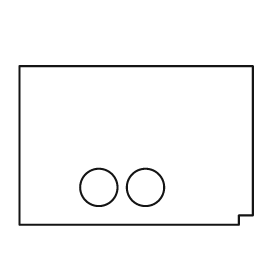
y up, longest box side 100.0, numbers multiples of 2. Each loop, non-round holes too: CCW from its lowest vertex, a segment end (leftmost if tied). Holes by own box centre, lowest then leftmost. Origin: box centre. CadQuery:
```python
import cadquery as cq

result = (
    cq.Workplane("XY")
    .moveTo(-50.0, -34.0)
    .lineTo(44.0, -34.0)
    .lineTo(44.0, -30.0)
    .lineTo(50.0, -30.0)
    .lineTo(50.0, 34.0)
    .lineTo(-50.0, 34.0)
    .close()
    .moveTo(-16.0, -18.0)
    .circle(8.0)
    .moveTo(4.0, -18.0)
    .circle(8.0)
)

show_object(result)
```